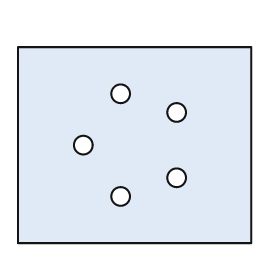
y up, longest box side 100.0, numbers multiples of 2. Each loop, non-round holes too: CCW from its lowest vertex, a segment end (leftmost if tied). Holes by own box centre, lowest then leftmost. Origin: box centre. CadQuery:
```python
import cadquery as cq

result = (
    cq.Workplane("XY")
    .moveTo(-50.0, -42.0)
    .lineTo(50.0, -42.0)
    .lineTo(50.0, 42.0)
    .lineTo(-50.0, 42.0)
    .close()
    .moveTo(-6.0, -22.0)
    .circle(4.0)
    .moveTo(18.0, -14.0)
    .circle(4.0)
    .moveTo(-22.0, 0.0)
    .circle(4.0)
    .moveTo(18.0, 14.0)
    .circle(4.0)
    .moveTo(-6.0, 22.0)
    .circle(4.0)
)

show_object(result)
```